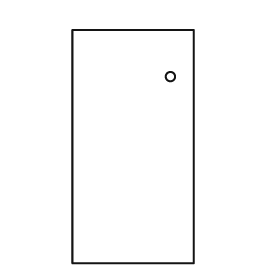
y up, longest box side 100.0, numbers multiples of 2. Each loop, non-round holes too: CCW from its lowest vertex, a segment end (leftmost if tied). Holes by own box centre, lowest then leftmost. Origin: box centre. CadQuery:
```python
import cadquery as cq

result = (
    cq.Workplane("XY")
    .moveTo(-26.0, -50.0)
    .lineTo(26.0, -50.0)
    .lineTo(26.0, 50.0)
    .lineTo(-26.0, 50.0)
    .close()
    .moveTo(16.0, 30.0)
    .circle(2.0)
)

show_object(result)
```